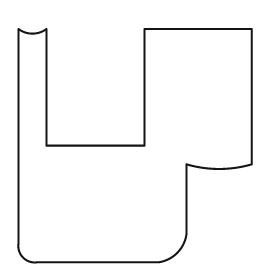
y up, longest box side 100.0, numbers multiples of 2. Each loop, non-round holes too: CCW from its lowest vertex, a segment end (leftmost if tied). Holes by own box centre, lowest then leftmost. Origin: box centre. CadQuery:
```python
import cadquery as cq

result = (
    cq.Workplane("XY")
    .moveTo(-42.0, -50.0)
    .lineTo(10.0, -50.0)
    .threePointArc((18.0, -46.0), (22.0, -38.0))
    .lineTo(22.0, -8.0)
    .threePointArc((36.0, -10.0), (50.0, -8.0))
    .lineTo(50.0, 50.0)
    .lineTo(4.0, 50.0)
    .lineTo(4.0, 0.0)
    .lineTo(-38.0, 0.0)
    .lineTo(-38.0, 50.0)
    .threePointArc((-44.0, 48.0), (-50.0, 50.0))
    .lineTo(-50.0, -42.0)
    .threePointArc((-48.0, -48.0), (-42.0, -50.0))
    .close()
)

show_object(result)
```